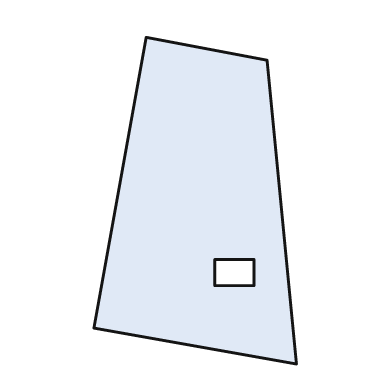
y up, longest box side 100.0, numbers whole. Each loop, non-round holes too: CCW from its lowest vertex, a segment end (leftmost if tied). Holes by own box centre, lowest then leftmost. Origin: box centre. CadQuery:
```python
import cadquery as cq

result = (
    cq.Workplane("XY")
    .moveTo(31.0, -50.0)
    .lineTo(22.0, 43.0)
    .lineTo(-15.0, 50.0)
    .lineTo(-31.0, -39.0)
    .close()
    .moveTo(6.0, -26.0)
    .lineTo(18.0, -26.0)
    .lineTo(18.0, -18.0)
    .lineTo(6.0, -18.0)
    .close()
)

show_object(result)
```